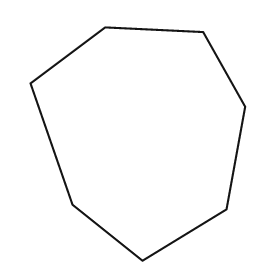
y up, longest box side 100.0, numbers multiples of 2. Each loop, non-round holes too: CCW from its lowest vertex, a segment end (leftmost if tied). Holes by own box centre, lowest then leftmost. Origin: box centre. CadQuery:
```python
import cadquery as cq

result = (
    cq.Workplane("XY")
    .moveTo(2.0, -50.0)
    .lineTo(38.0, -28.0)
    .lineTo(46.0, 16.0)
    .lineTo(28.0, 48.0)
    .lineTo(-14.0, 50.0)
    .lineTo(-46.0, 26.0)
    .lineTo(-28.0, -26.0)
    .close()
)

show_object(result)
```